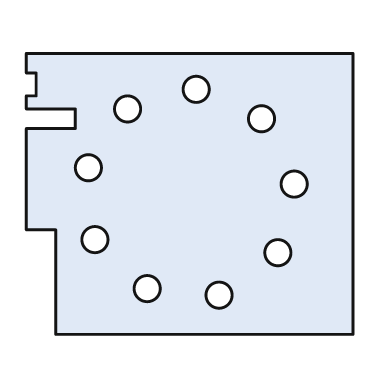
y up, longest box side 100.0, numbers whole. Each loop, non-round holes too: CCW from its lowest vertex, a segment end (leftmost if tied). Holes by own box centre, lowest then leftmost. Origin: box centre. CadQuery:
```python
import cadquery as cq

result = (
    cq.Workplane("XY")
    .moveTo(-41.0, -43.0)
    .lineTo(50.0, -43.0)
    .lineTo(50.0, 43.0)
    .lineTo(-50.0, 43.0)
    .lineTo(-50.0, 37.0)
    .lineTo(-47.0, 37.0)
    .lineTo(-47.0, 30.0)
    .lineTo(-50.0, 30.0)
    .lineTo(-50.0, 26.0)
    .lineTo(-35.0, 26.0)
    .lineTo(-35.0, 20.0)
    .lineTo(-50.0, 20.0)
    .lineTo(-50.0, -11.0)
    .lineTo(-41.0, -11.0)
    .close()
    .moveTo(9.0, -31.0)
    .circle(4.0)
    .moveTo(-13.0, -29.0)
    .circle(4.0)
    .moveTo(27.0, -18.0)
    .circle(4.0)
    .moveTo(-29.0, -14.0)
    .circle(4.0)
    .moveTo(32.0, 3.0)
    .circle(4.0)
    .moveTo(-31.0, 8.0)
    .circle(4.0)
    .moveTo(22.0, 23.0)
    .circle(4.0)
    .moveTo(-19.0, 26.0)
    .circle(4.0)
    .moveTo(2.0, 32.0)
    .circle(4.0)
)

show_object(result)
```